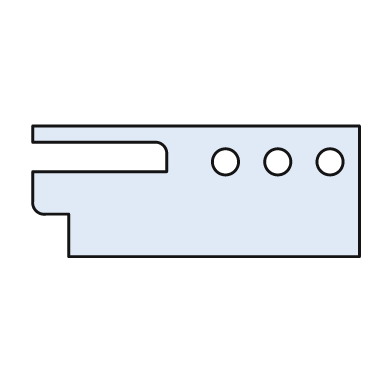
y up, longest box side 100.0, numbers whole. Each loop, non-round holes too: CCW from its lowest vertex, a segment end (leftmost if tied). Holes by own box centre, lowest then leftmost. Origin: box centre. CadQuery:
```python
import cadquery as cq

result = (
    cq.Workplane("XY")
    .moveTo(-39.0, -20.0)
    .lineTo(50.0, -20.0)
    .lineTo(50.0, 20.0)
    .lineTo(-50.0, 20.0)
    .lineTo(-50.0, 15.0)
    .lineTo(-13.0, 15.0)
    .threePointArc((-10.0, 14.0), (-9.0, 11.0))
    .lineTo(-9.0, 6.0)
    .lineTo(-50.0, 6.0)
    .lineTo(-50.0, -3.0)
    .threePointArc((-49.0, -6.0), (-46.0, -7.0))
    .lineTo(-39.0, -7.0)
    .close()
    .moveTo(9.0, 9.0)
    .circle(4.0)
    .moveTo(25.0, 9.0)
    .circle(4.0)
    .moveTo(41.0, 9.0)
    .circle(4.0)
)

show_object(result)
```